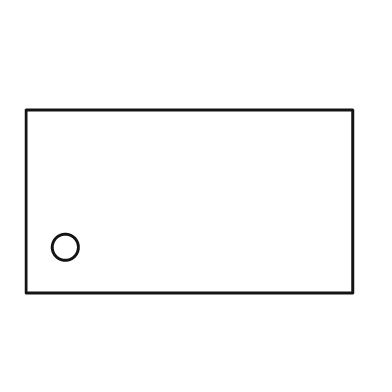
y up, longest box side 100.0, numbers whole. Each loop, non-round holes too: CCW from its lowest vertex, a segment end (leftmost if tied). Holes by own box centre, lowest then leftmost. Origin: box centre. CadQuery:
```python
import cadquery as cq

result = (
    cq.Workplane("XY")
    .moveTo(-50.0, -28.0)
    .lineTo(50.0, -28.0)
    .lineTo(50.0, 28.0)
    .lineTo(-50.0, 28.0)
    .close()
    .moveTo(-38.0, -14.0)
    .circle(4.0)
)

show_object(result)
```